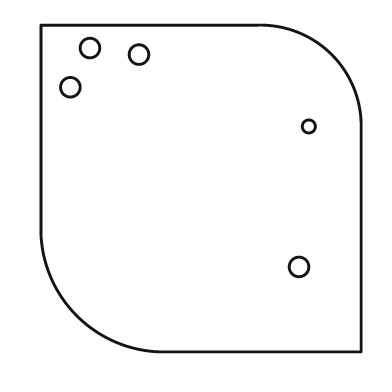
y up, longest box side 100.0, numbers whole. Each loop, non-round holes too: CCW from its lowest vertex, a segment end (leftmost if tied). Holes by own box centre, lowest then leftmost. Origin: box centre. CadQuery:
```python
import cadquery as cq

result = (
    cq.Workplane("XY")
    .moveTo(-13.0, -50.0)
    .lineTo(49.0, -50.0)
    .lineTo(49.0, 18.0)
    .threePointArc((40.0, 41.0), (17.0, 50.0))
    .lineTo(-49.0, 50.0)
    .lineTo(-49.0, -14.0)
    .threePointArc((-38.0, -39.0), (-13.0, -50.0))
    .close()
    .moveTo(30.0, -24.0)
    .circle(3.0)
    .moveTo(33.0, 19.0)
    .circle(2.0)
    .moveTo(-40.0, 31.0)
    .circle(3.0)
    .moveTo(-19.0, 41.0)
    .circle(3.0)
    .moveTo(-34.0, 43.0)
    .circle(3.0)
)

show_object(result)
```